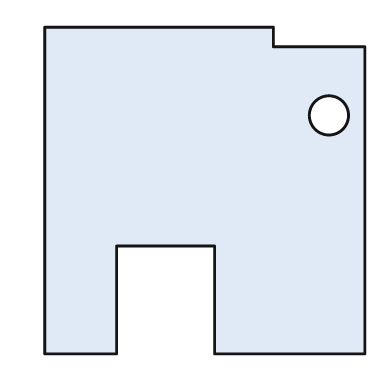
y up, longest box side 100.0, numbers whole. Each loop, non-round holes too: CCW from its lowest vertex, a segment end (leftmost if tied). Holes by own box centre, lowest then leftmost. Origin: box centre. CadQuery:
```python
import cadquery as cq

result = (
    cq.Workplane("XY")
    .moveTo(-49.0, -50.0)
    .lineTo(-27.0, -50.0)
    .lineTo(-27.0, -17.0)
    .lineTo(3.0, -17.0)
    .lineTo(3.0, -50.0)
    .lineTo(49.0, -50.0)
    .lineTo(49.0, 44.0)
    .lineTo(21.0, 44.0)
    .lineTo(21.0, 50.0)
    .lineTo(-49.0, 50.0)
    .close()
    .moveTo(38.0, 23.0)
    .circle(6.0)
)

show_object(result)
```